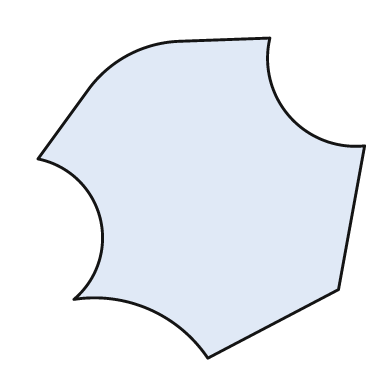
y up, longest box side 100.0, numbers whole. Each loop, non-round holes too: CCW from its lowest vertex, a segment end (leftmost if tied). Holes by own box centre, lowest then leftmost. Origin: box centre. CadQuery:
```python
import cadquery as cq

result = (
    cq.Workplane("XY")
    .moveTo(2.0, -49.0)
    .lineTo(42.0, -28.0)
    .lineTo(50.0, 16.0)
    .threePointArc((27.0, 25.0), (21.0, 49.0))
    .lineTo(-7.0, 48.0)
    .threePointArc((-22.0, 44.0), (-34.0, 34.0))
    .lineTo(-50.0, 12.0)
    .threePointArc((-31.0, -6.0), (-39.0, -31.0))
    .threePointArc((-16.0, -34.0), (2.0, -49.0))
    .close()
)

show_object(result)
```